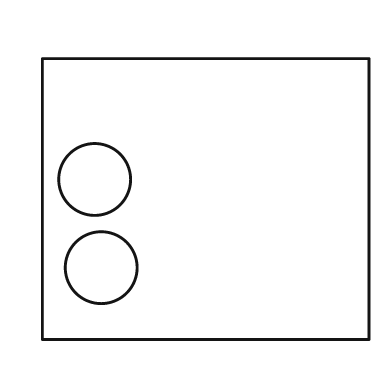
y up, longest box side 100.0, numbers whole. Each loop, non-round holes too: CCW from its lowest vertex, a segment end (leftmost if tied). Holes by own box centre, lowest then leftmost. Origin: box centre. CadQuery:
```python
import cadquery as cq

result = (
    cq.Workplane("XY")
    .moveTo(-50.0, -43.0)
    .lineTo(50.0, -43.0)
    .lineTo(50.0, 43.0)
    .lineTo(-50.0, 43.0)
    .close()
    .moveTo(-32.0, -21.0)
    .circle(11.0)
    .moveTo(-34.0, 6.0)
    .circle(11.0)
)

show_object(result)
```